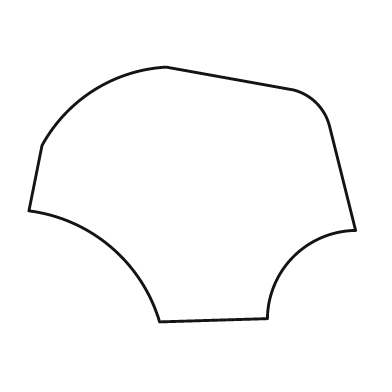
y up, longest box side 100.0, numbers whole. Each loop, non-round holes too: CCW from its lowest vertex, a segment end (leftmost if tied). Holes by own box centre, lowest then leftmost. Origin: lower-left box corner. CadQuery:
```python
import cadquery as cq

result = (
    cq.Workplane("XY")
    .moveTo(40.0, 0.0)
    .lineTo(73.0, 1.0)
    .threePointArc((81.0, 20.0), (100.0, 28.0))
    .lineTo(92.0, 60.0)
    .threePointArc((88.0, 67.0), (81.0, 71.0))
    .lineTo(42.0, 78.0)
    .threePointArc((20.0, 71.0), (4.0, 54.0))
    .lineTo(0.0, 34.0)
    .threePointArc((25.0, 23.0), (40.0, 0.0))
    .close()
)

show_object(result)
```